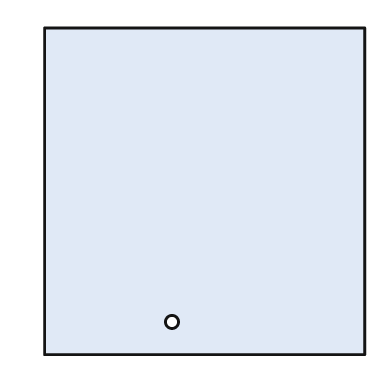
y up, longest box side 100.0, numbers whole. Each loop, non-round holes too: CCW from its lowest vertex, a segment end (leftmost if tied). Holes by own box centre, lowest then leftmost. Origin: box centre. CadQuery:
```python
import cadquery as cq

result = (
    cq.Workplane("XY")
    .moveTo(-49.0, -50.0)
    .lineTo(49.0, -50.0)
    .lineTo(49.0, 50.0)
    .lineTo(-49.0, 50.0)
    .close()
    .moveTo(-10.0, -40.0)
    .circle(2.0)
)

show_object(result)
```